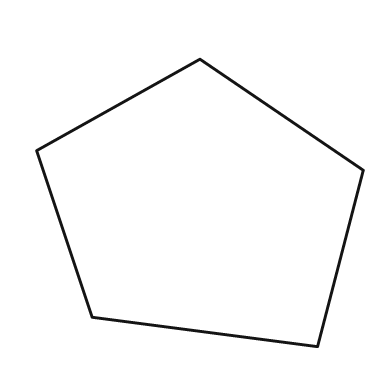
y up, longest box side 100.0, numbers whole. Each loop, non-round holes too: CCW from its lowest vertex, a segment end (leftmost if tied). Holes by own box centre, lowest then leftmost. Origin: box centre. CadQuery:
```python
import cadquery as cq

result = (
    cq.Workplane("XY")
    .moveTo(36.0, -44.0)
    .lineTo(50.0, 10.0)
    .lineTo(0.0, 44.0)
    .lineTo(-50.0, 16.0)
    .lineTo(-33.0, -35.0)
    .close()
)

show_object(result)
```